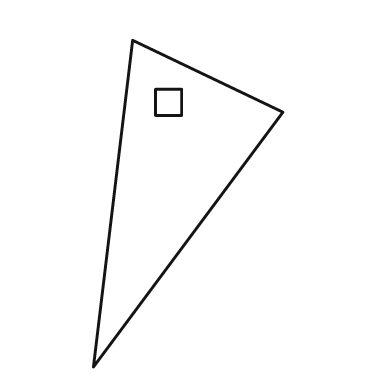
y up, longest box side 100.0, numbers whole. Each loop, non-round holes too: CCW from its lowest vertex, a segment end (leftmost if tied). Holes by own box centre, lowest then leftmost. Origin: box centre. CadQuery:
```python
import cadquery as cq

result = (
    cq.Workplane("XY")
    .moveTo(-29.0, -50.0)
    .lineTo(29.0, 28.0)
    .lineTo(-17.0, 50.0)
    .close()
    .moveTo(-10.0, 27.0)
    .lineTo(-2.0, 27.0)
    .lineTo(-2.0, 35.0)
    .lineTo(-10.0, 35.0)
    .close()
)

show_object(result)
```